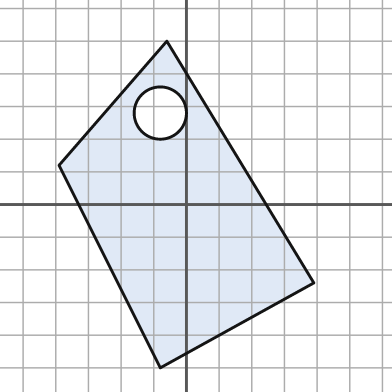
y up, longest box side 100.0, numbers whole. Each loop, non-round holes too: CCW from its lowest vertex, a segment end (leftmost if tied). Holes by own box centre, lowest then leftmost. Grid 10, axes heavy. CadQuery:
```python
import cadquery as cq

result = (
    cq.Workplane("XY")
    .moveTo(-8.0, -50.0)
    .lineTo(39.0, -24.0)
    .lineTo(-6.0, 50.0)
    .lineTo(-39.0, 12.0)
    .close()
    .moveTo(-8.0, 28.0)
    .circle(8.0)
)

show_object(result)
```